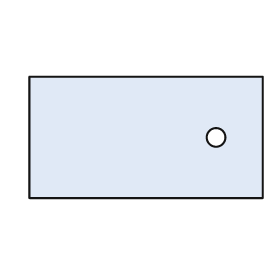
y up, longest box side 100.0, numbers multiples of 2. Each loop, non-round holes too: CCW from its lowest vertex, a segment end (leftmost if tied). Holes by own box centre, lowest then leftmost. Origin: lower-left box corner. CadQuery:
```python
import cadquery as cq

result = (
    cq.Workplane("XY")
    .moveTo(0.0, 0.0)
    .lineTo(100.0, 0.0)
    .lineTo(100.0, 52.0)
    .lineTo(0.0, 52.0)
    .close()
    .moveTo(80.0, 26.0)
    .circle(4.0)
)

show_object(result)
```